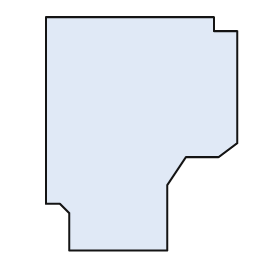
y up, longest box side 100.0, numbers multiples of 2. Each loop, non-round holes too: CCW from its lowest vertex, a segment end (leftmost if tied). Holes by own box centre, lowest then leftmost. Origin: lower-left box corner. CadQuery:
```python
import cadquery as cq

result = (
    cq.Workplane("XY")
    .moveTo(10.0, 0.0)
    .lineTo(52.0, 0.0)
    .lineTo(52.0, 28.0)
    .lineTo(60.0, 40.0)
    .lineTo(74.0, 40.0)
    .lineTo(82.0, 46.0)
    .lineTo(82.0, 94.0)
    .lineTo(72.0, 94.0)
    .lineTo(72.0, 100.0)
    .lineTo(0.0, 100.0)
    .lineTo(0.0, 20.0)
    .lineTo(6.0, 20.0)
    .lineTo(10.0, 16.0)
    .close()
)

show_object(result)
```